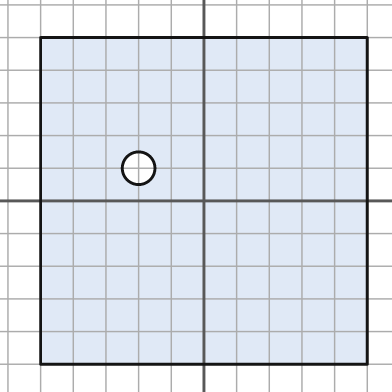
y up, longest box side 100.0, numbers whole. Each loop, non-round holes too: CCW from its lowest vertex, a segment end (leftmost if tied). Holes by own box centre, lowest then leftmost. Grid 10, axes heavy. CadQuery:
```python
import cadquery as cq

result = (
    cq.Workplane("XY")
    .moveTo(-50.0, -50.0)
    .lineTo(50.0, -50.0)
    .lineTo(50.0, 50.0)
    .lineTo(-50.0, 50.0)
    .close()
    .moveTo(-20.0, 10.0)
    .circle(5.0)
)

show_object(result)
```